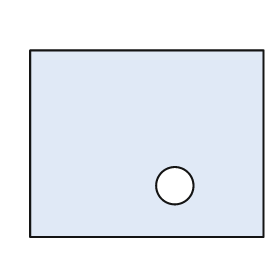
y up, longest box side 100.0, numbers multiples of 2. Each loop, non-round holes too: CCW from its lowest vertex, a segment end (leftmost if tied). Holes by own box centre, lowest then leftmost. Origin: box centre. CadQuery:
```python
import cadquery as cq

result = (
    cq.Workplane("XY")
    .moveTo(-50.0, -40.0)
    .lineTo(50.0, -40.0)
    .lineTo(50.0, 40.0)
    .lineTo(-50.0, 40.0)
    .close()
    .moveTo(12.0, -18.0)
    .circle(8.0)
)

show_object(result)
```